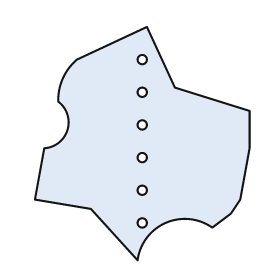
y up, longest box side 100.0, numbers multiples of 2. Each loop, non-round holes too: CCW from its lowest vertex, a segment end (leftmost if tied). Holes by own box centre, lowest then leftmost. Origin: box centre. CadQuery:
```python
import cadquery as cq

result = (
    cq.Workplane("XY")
    .moveTo(-2.0, -50.0)
    .threePointArc((10.0, -34.0), (30.0, -36.0))
    .lineTo(38.0, -30.0)
    .lineTo(42.0, -24.0)
    .lineTo(46.0, -2.0)
    .lineTo(46.0, 14.0)
    .lineTo(14.0, 24.0)
    .lineTo(2.0, 50.0)
    .lineTo(-28.0, 36.0)
    .threePointArc((-34.0, 28.0), (-36.0, 18.0))
    .threePointArc((-32.0, 6.0), (-42.0, -2.0))
    .lineTo(-46.0, -24.0)
    .lineTo(-22.0, -28.0)
    .close()
    .moveTo(0.0, -34.0)
    .circle(2.0)
    .moveTo(0.0, -20.0)
    .circle(2.0)
    .moveTo(0.0, -6.0)
    .circle(2.0)
    .moveTo(0.0, 8.0)
    .circle(2.0)
    .moveTo(0.0, 22.0)
    .circle(2.0)
    .moveTo(0.0, 36.0)
    .circle(2.0)
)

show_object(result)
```